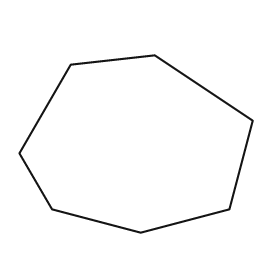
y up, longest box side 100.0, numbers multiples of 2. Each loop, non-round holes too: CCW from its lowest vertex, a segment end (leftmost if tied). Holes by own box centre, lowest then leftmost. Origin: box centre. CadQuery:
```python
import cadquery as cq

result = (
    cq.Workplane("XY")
    .moveTo(2.0, -38.0)
    .lineTo(40.0, -28.0)
    .lineTo(50.0, 10.0)
    .lineTo(8.0, 38.0)
    .lineTo(-28.0, 34.0)
    .lineTo(-50.0, -4.0)
    .lineTo(-36.0, -28.0)
    .close()
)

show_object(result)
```